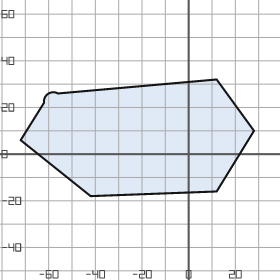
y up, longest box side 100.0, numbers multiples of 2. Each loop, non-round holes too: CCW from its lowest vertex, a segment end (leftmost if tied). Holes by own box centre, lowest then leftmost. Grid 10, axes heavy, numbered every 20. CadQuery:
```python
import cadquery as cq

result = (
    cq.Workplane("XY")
    .moveTo(-42.0, -18.0)
    .lineTo(12.0, -16.0)
    .lineTo(28.0, 10.0)
    .lineTo(12.0, 32.0)
    .lineTo(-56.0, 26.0)
    .threePointArc((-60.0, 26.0), (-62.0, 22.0))
    .lineTo(-72.0, 6.0)
    .close()
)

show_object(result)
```